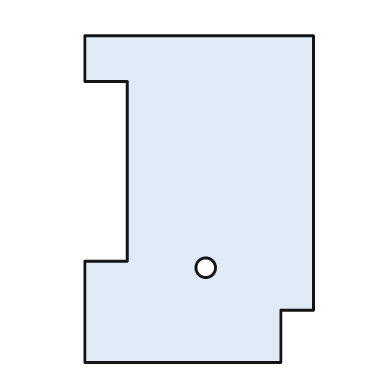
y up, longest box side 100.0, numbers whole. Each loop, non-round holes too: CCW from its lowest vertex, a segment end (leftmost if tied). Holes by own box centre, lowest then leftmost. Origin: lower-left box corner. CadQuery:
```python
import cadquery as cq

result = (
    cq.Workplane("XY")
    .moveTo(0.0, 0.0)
    .lineTo(60.0, 0.0)
    .lineTo(60.0, 16.0)
    .lineTo(70.0, 16.0)
    .lineTo(70.0, 100.0)
    .lineTo(0.0, 100.0)
    .lineTo(0.0, 86.0)
    .lineTo(13.0, 86.0)
    .lineTo(13.0, 31.0)
    .lineTo(0.0, 31.0)
    .close()
    .moveTo(37.0, 29.0)
    .circle(3.0)
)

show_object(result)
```